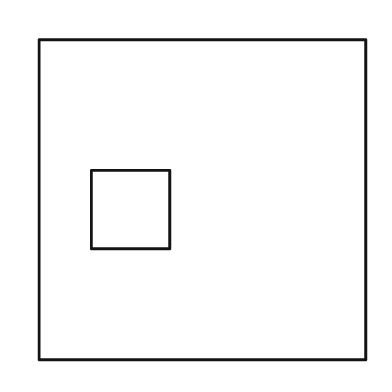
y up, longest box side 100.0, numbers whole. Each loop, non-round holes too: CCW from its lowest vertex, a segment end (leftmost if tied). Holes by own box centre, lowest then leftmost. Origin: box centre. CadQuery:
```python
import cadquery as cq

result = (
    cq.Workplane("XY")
    .moveTo(-50.0, -49.0)
    .lineTo(50.0, -49.0)
    .lineTo(50.0, 49.0)
    .lineTo(-50.0, 49.0)
    .close()
    .moveTo(-34.0, -15.0)
    .lineTo(-10.0, -15.0)
    .lineTo(-10.0, 9.0)
    .lineTo(-34.0, 9.0)
    .close()
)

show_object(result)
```